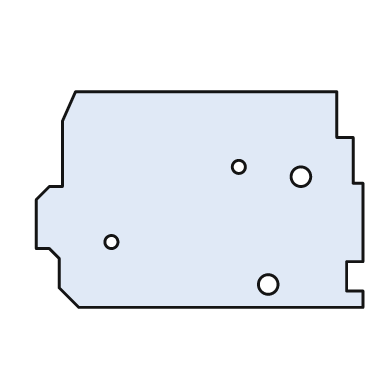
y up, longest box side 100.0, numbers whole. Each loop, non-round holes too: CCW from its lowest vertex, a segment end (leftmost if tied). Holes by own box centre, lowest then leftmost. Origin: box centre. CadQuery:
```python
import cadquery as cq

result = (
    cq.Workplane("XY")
    .moveTo(-37.0, -33.0)
    .lineTo(50.0, -33.0)
    .lineTo(50.0, -28.0)
    .lineTo(45.0, -28.0)
    .lineTo(45.0, -19.0)
    .lineTo(50.0, -19.0)
    .lineTo(50.0, 5.0)
    .lineTo(47.0, 5.0)
    .lineTo(47.0, 19.0)
    .lineTo(42.0, 19.0)
    .lineTo(42.0, 33.0)
    .lineTo(-38.0, 33.0)
    .lineTo(-42.0, 24.0)
    .lineTo(-42.0, 4.0)
    .lineTo(-46.0, 4.0)
    .lineTo(-50.0, 0.0)
    .lineTo(-50.0, -15.0)
    .lineTo(-46.0, -15.0)
    .lineTo(-43.0, -18.0)
    .lineTo(-43.0, -27.0)
    .close()
    .moveTo(21.0, -26.0)
    .circle(3.0)
    .moveTo(-27.0, -13.0)
    .circle(2.0)
    .moveTo(31.0, 7.0)
    .circle(3.0)
    .moveTo(12.0, 10.0)
    .circle(2.0)
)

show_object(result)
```